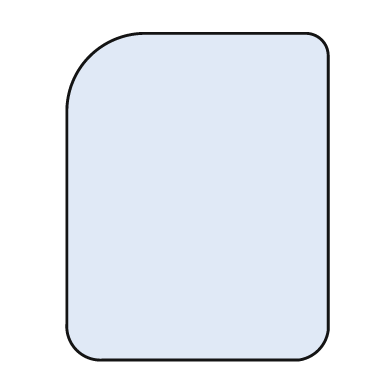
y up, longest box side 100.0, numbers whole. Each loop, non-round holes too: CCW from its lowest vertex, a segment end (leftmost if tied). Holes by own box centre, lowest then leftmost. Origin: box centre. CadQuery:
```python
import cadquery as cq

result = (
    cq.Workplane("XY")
    .moveTo(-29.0, -50.0)
    .lineTo(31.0, -50.0)
    .threePointArc((37.0, -47.0), (40.0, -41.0))
    .lineTo(40.0, 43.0)
    .threePointArc((38.0, 48.0), (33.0, 50.0))
    .lineTo(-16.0, 50.0)
    .threePointArc((-33.0, 43.0), (-40.0, 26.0))
    .lineTo(-40.0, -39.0)
    .threePointArc((-37.0, -47.0), (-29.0, -50.0))
    .close()
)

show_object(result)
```